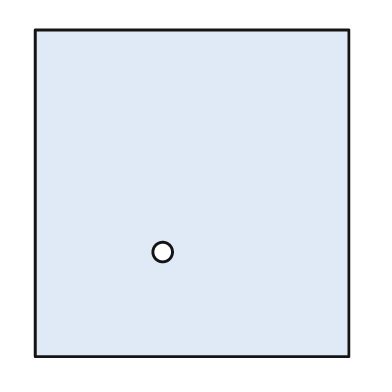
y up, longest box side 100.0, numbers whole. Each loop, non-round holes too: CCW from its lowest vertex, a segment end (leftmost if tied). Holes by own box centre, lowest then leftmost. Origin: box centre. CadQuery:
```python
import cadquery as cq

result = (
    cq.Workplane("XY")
    .moveTo(-48.0, -50.0)
    .lineTo(48.0, -50.0)
    .lineTo(48.0, 50.0)
    .lineTo(-48.0, 50.0)
    .close()
    .moveTo(-9.0, -18.0)
    .circle(3.0)
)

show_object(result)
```